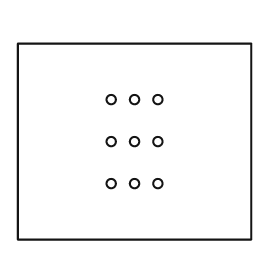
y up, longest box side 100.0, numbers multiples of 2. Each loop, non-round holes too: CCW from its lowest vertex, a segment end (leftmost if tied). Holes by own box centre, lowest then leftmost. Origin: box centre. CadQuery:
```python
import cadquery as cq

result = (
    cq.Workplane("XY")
    .moveTo(-50.0, -42.0)
    .lineTo(50.0, -42.0)
    .lineTo(50.0, 42.0)
    .lineTo(-50.0, 42.0)
    .close()
    .moveTo(-10.0, -18.0)
    .circle(2.0)
    .moveTo(0.0, -18.0)
    .circle(2.0)
    .moveTo(10.0, -18.0)
    .circle(2.0)
    .moveTo(-10.0, 0.0)
    .circle(2.0)
    .moveTo(0.0, 0.0)
    .circle(2.0)
    .moveTo(10.0, 0.0)
    .circle(2.0)
    .moveTo(-10.0, 18.0)
    .circle(2.0)
    .moveTo(0.0, 18.0)
    .circle(2.0)
    .moveTo(10.0, 18.0)
    .circle(2.0)
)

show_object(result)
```